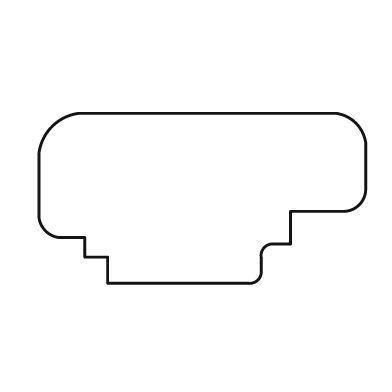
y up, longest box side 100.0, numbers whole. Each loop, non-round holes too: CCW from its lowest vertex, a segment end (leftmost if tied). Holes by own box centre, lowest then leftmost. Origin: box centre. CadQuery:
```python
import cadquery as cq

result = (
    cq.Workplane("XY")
    .moveTo(-29.0, -26.0)
    .lineTo(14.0, -26.0)
    .threePointArc((17.0, -25.0), (18.0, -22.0))
    .lineTo(18.0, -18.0)
    .threePointArc((19.0, -15.0), (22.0, -14.0))
    .lineTo(27.0, -14.0)
    .lineTo(27.0, -4.0)
    .lineTo(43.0, -4.0)
    .threePointArc((48.0, -2.0), (50.0, 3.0))
    .lineTo(50.0, 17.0)
    .threePointArc((47.0, 23.0), (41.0, 26.0))
    .lineTo(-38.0, 26.0)
    .threePointArc((-46.0, 22.0), (-50.0, 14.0))
    .lineTo(-50.0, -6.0)
    .threePointArc((-48.0, -10.0), (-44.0, -12.0))
    .lineTo(-36.0, -12.0)
    .lineTo(-36.0, -18.0)
    .lineTo(-29.0, -18.0)
    .close()
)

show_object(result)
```